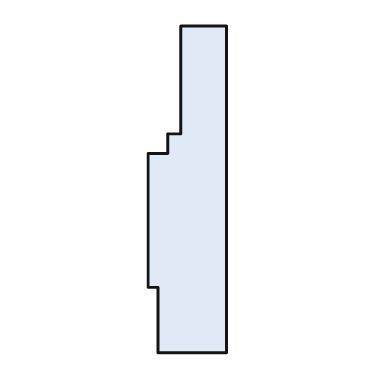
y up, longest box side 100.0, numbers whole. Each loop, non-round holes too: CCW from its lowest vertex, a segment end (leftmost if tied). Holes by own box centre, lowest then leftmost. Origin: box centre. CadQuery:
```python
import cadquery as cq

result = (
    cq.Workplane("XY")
    .moveTo(-9.0, -50.0)
    .lineTo(12.0, -50.0)
    .lineTo(12.0, 50.0)
    .lineTo(-2.0, 50.0)
    .lineTo(-2.0, 17.0)
    .lineTo(-6.0, 17.0)
    .lineTo(-6.0, 11.0)
    .lineTo(-12.0, 11.0)
    .lineTo(-12.0, -30.0)
    .lineTo(-9.0, -30.0)
    .close()
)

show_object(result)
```